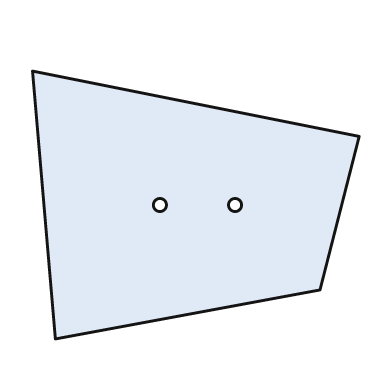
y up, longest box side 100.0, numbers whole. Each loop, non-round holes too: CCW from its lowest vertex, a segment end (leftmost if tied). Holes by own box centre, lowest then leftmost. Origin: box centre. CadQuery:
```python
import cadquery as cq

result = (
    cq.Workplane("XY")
    .moveTo(-43.0, -41.0)
    .lineTo(38.0, -26.0)
    .lineTo(50.0, 21.0)
    .lineTo(-50.0, 41.0)
    .close()
    .moveTo(-11.0, 0.0)
    .circle(2.0)
    .moveTo(12.0, 0.0)
    .circle(2.0)
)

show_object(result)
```